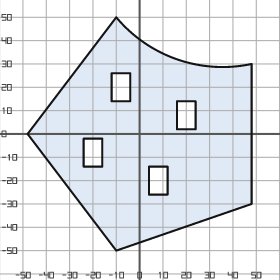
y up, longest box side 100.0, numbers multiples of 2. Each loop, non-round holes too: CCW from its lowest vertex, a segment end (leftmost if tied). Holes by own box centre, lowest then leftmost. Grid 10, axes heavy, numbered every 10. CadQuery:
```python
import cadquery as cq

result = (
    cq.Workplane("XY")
    .moveTo(-10.0, -50.0)
    .lineTo(48.0, -30.0)
    .lineTo(48.0, 30.0)
    .threePointArc((16.0, 32.0), (-10.0, 50.0))
    .lineTo(-48.0, 0.0)
    .close()
    .moveTo(4.0, -26.0)
    .lineTo(12.0, -26.0)
    .lineTo(12.0, -14.0)
    .lineTo(4.0, -14.0)
    .close()
    .moveTo(-24.0, -14.0)
    .lineTo(-16.0, -14.0)
    .lineTo(-16.0, -2.0)
    .lineTo(-24.0, -2.0)
    .close()
    .moveTo(16.0, 2.0)
    .lineTo(24.0, 2.0)
    .lineTo(24.0, 14.0)
    .lineTo(16.0, 14.0)
    .close()
    .moveTo(-12.0, 14.0)
    .lineTo(-4.0, 14.0)
    .lineTo(-4.0, 26.0)
    .lineTo(-12.0, 26.0)
    .close()
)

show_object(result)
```